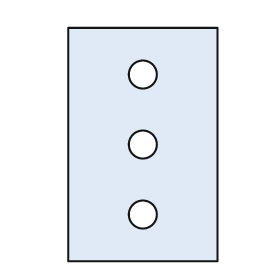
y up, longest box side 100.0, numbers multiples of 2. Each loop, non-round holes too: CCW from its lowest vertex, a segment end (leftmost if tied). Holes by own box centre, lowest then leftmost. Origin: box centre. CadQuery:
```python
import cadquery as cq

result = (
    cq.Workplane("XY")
    .moveTo(-32.0, -50.0)
    .lineTo(32.0, -50.0)
    .lineTo(32.0, 50.0)
    .lineTo(-32.0, 50.0)
    .close()
    .moveTo(0.0, -30.0)
    .circle(6.0)
    .moveTo(0.0, 0.0)
    .circle(6.0)
    .moveTo(0.0, 30.0)
    .circle(6.0)
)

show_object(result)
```